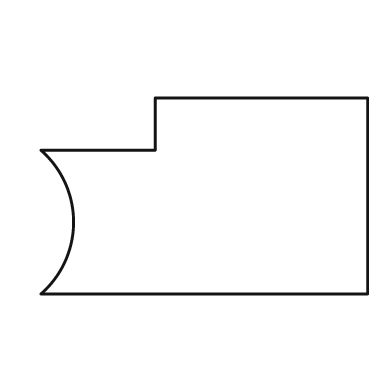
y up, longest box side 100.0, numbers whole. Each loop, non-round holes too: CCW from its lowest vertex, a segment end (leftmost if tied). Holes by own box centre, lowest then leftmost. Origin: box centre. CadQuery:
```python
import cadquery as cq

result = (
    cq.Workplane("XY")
    .moveTo(-50.0, -30.0)
    .lineTo(50.0, -30.0)
    .lineTo(50.0, 30.0)
    .lineTo(-15.0, 30.0)
    .lineTo(-15.0, 14.0)
    .lineTo(-50.0, 14.0)
    .threePointArc((-40.0, -8.0), (-50.0, -30.0))
    .close()
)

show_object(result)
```